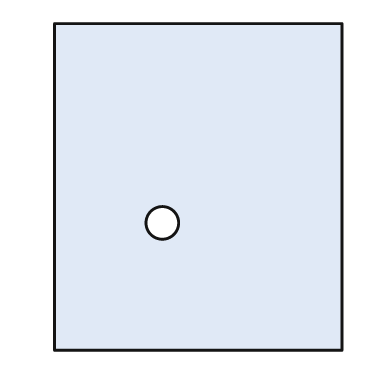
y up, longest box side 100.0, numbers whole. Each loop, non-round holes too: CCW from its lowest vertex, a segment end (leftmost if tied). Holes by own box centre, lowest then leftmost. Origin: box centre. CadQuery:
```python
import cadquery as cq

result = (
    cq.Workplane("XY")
    .moveTo(-44.0, -50.0)
    .lineTo(44.0, -50.0)
    .lineTo(44.0, 50.0)
    .lineTo(-44.0, 50.0)
    .close()
    .moveTo(-11.0, -11.0)
    .circle(5.0)
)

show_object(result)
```